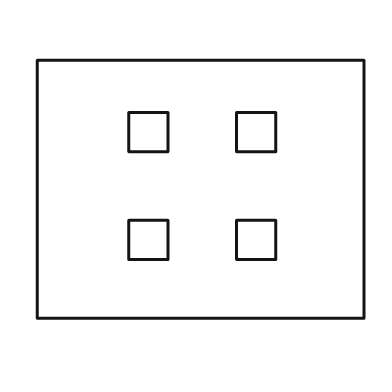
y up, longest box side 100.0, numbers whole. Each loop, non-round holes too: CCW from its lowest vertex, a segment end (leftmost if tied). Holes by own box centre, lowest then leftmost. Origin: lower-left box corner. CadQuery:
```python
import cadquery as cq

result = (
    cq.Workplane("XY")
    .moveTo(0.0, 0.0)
    .lineTo(100.0, 0.0)
    .lineTo(100.0, 79.0)
    .lineTo(0.0, 79.0)
    .close()
    .moveTo(28.0, 18.0)
    .lineTo(40.0, 18.0)
    .lineTo(40.0, 30.0)
    .lineTo(28.0, 30.0)
    .close()
    .moveTo(61.0, 18.0)
    .lineTo(73.0, 18.0)
    .lineTo(73.0, 30.0)
    .lineTo(61.0, 30.0)
    .close()
    .moveTo(28.0, 51.0)
    .lineTo(40.0, 51.0)
    .lineTo(40.0, 63.0)
    .lineTo(28.0, 63.0)
    .close()
    .moveTo(61.0, 51.0)
    .lineTo(73.0, 51.0)
    .lineTo(73.0, 63.0)
    .lineTo(61.0, 63.0)
    .close()
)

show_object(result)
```